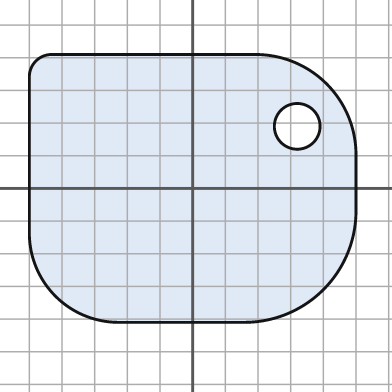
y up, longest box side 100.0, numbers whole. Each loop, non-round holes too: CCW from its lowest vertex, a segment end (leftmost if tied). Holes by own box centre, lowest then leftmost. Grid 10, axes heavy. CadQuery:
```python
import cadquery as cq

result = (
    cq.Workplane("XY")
    .moveTo(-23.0, -41.0)
    .lineTo(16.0, -41.0)
    .threePointArc((40.0, -31.0), (50.0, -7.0))
    .lineTo(50.0, 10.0)
    .threePointArc((41.0, 32.0), (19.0, 41.0))
    .lineTo(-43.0, 41.0)
    .threePointArc((-48.0, 39.0), (-50.0, 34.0))
    .lineTo(-50.0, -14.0)
    .threePointArc((-42.0, -33.0), (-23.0, -41.0))
    .close()
    .moveTo(32.0, 19.0)
    .circle(7.0)
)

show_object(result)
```